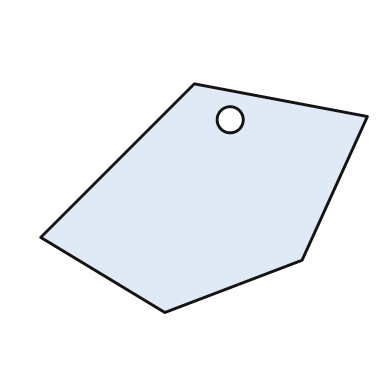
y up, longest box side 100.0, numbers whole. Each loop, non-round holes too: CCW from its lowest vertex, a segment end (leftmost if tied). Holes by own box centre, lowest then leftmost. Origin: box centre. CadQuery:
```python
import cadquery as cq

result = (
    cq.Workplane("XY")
    .moveTo(-12.0, -35.0)
    .lineTo(30.0, -19.0)
    .lineTo(50.0, 25.0)
    .lineTo(-3.0, 35.0)
    .lineTo(-50.0, -12.0)
    .close()
    .moveTo(8.0, 24.0)
    .circle(4.0)
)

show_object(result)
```